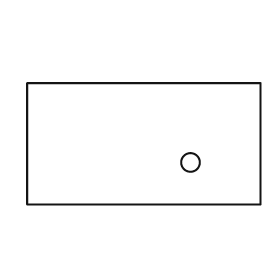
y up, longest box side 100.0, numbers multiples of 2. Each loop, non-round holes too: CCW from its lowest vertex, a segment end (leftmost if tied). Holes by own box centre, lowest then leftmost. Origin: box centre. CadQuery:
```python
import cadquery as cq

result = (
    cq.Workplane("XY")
    .moveTo(-50.0, -26.0)
    .lineTo(50.0, -26.0)
    .lineTo(50.0, 26.0)
    .lineTo(-50.0, 26.0)
    .close()
    .moveTo(20.0, -8.0)
    .circle(4.0)
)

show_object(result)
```